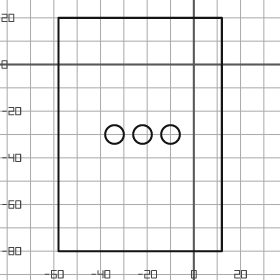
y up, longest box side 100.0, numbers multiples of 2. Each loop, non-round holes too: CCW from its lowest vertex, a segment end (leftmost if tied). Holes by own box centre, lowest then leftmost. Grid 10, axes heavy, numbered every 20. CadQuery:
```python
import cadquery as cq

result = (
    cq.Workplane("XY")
    .moveTo(-58.0, -80.0)
    .lineTo(12.0, -80.0)
    .lineTo(12.0, 20.0)
    .lineTo(-58.0, 20.0)
    .close()
    .moveTo(-34.0, -30.0)
    .circle(4.0)
    .moveTo(-22.0, -30.0)
    .circle(4.0)
    .moveTo(-10.0, -30.0)
    .circle(4.0)
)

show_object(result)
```